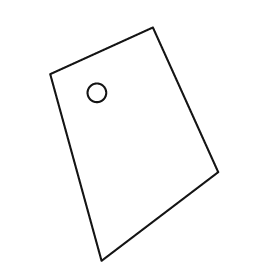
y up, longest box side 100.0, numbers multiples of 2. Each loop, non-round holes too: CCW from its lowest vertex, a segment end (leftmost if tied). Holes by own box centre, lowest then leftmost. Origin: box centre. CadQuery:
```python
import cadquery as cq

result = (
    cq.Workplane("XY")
    .moveTo(-14.0, -50.0)
    .lineTo(36.0, -12.0)
    .lineTo(8.0, 50.0)
    .lineTo(-36.0, 30.0)
    .close()
    .moveTo(-16.0, 22.0)
    .circle(4.0)
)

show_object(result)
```